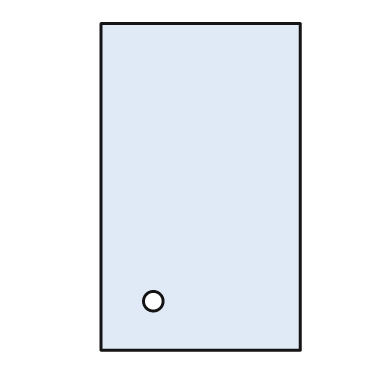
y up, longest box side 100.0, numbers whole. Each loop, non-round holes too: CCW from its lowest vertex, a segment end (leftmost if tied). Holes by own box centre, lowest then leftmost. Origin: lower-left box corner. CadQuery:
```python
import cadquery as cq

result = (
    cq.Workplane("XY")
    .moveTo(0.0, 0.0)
    .lineTo(61.0, 0.0)
    .lineTo(61.0, 100.0)
    .lineTo(0.0, 100.0)
    .close()
    .moveTo(16.0, 15.0)
    .circle(3.0)
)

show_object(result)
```